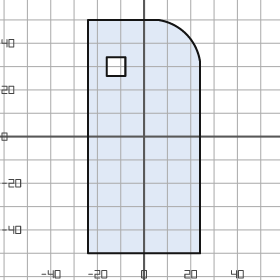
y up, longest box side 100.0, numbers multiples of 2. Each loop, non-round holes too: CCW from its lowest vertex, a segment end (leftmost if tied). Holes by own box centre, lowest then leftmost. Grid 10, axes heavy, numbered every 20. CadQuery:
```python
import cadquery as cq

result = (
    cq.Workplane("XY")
    .moveTo(-24.0, -50.0)
    .lineTo(24.0, -50.0)
    .lineTo(24.0, 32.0)
    .threePointArc((18.0, 44.0), (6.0, 50.0))
    .lineTo(-24.0, 50.0)
    .close()
    .moveTo(-16.0, 26.0)
    .lineTo(-8.0, 26.0)
    .lineTo(-8.0, 34.0)
    .lineTo(-16.0, 34.0)
    .close()
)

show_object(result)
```